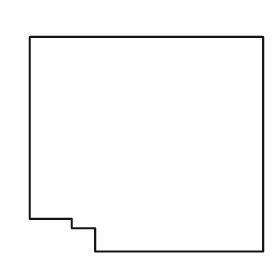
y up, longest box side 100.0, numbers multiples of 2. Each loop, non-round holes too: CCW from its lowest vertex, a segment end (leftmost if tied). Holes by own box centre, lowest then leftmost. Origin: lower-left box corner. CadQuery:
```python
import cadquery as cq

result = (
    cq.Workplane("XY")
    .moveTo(28.0, 0.0)
    .lineTo(100.0, 0.0)
    .lineTo(100.0, 92.0)
    .lineTo(0.0, 92.0)
    .lineTo(0.0, 14.0)
    .lineTo(18.0, 14.0)
    .lineTo(18.0, 10.0)
    .lineTo(28.0, 10.0)
    .close()
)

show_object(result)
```